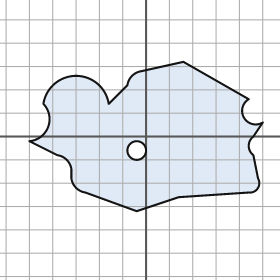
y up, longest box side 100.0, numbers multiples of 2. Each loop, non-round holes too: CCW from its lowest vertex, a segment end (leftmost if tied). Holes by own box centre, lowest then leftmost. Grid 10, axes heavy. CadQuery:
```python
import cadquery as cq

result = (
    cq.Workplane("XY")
    .moveTo(-4.0, -32.0)
    .lineTo(14.0, -26.0)
    .lineTo(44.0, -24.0)
    .threePointArc((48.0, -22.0), (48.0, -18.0))
    .lineTo(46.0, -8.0)
    .threePointArc((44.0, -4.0), (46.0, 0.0))
    .lineTo(50.0, 6.0)
    .threePointArc((42.0, 8.0), (44.0, 16.0))
    .lineTo(16.0, 32.0)
    .lineTo(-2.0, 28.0)
    .threePointArc((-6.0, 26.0), (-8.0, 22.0))
    .lineTo(-16.0, 14.0)
    .threePointArc((-30.0, 26.0), (-44.0, 14.0))
    .threePointArc((-42.0, 4.0), (-50.0, -2.0))
    .lineTo(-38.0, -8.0)
    .threePointArc((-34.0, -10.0), (-32.0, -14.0))
    .lineTo(-32.0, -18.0)
    .threePointArc((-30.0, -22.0), (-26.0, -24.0))
    .close()
    .moveTo(-4.0, -6.0)
    .circle(4.0)
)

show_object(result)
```